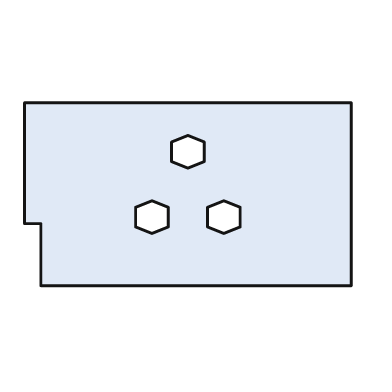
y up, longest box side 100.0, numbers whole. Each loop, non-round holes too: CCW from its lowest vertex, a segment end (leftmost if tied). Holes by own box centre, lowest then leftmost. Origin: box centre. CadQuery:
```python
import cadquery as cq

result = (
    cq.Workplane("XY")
    .moveTo(-45.0, -28.0)
    .lineTo(50.0, -28.0)
    .lineTo(50.0, 28.0)
    .lineTo(-50.0, 28.0)
    .lineTo(-50.0, -9.0)
    .lineTo(-45.0, -9.0)
    .close()
    .moveTo(-11.0, -12.0)
    .lineTo(-6.0, -10.0)
    .lineTo(-6.0, -4.0)
    .lineTo(-11.0, -2.0)
    .lineTo(-16.0, -4.0)
    .lineTo(-16.0, -10.0)
    .close()
    .moveTo(11.0, -12.0)
    .lineTo(16.0, -10.0)
    .lineTo(16.0, -4.0)
    .lineTo(11.0, -2.0)
    .lineTo(6.0, -4.0)
    .lineTo(6.0, -10.0)
    .close()
    .moveTo(0.0, 8.0)
    .lineTo(5.0, 10.0)
    .lineTo(5.0, 16.0)
    .lineTo(0.0, 18.0)
    .lineTo(-5.0, 16.0)
    .lineTo(-5.0, 10.0)
    .close()
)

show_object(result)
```